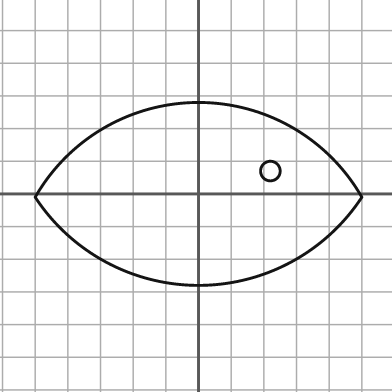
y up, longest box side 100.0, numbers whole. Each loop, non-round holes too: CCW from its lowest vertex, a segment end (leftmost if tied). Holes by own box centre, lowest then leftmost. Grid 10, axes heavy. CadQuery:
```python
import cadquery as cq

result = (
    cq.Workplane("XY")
    .moveTo(-50.0, -1.0)
    .threePointArc((0.0, -28.0), (50.0, -1.0))
    .threePointArc((0.0, 28.0), (-50.0, -1.0))
    .close()
    .moveTo(22.0, 7.0)
    .circle(3.0)
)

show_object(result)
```